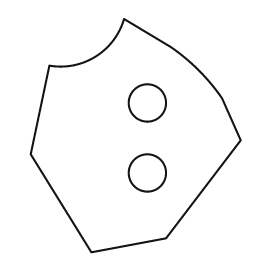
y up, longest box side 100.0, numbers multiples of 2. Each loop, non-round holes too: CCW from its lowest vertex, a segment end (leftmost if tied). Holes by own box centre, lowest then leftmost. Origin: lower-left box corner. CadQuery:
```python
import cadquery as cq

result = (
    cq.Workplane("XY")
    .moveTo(26.0, 0.0)
    .lineTo(58.0, 6.0)
    .lineTo(90.0, 48.0)
    .lineTo(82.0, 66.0)
    .threePointArc((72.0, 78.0), (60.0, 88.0))
    .lineTo(40.0, 100.0)
    .threePointArc((28.0, 84.0), (8.0, 80.0))
    .lineTo(0.0, 42.0)
    .close()
    .moveTo(50.0, 34.0)
    .circle(8.0)
    .moveTo(50.0, 64.0)
    .circle(8.0)
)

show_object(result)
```